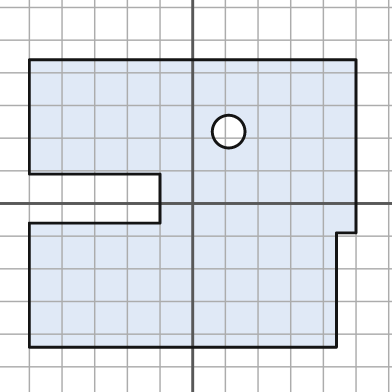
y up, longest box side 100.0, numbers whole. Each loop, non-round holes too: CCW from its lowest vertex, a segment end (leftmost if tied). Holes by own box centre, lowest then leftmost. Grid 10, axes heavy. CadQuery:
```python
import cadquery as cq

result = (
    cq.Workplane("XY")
    .moveTo(-50.0, -44.0)
    .lineTo(44.0, -44.0)
    .lineTo(44.0, -9.0)
    .lineTo(50.0, -9.0)
    .lineTo(50.0, 44.0)
    .lineTo(-50.0, 44.0)
    .lineTo(-50.0, 9.0)
    .lineTo(-10.0, 9.0)
    .lineTo(-10.0, -6.0)
    .lineTo(-50.0, -6.0)
    .close()
    .moveTo(11.0, 22.0)
    .circle(5.0)
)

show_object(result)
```